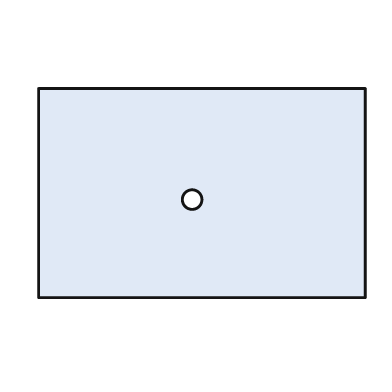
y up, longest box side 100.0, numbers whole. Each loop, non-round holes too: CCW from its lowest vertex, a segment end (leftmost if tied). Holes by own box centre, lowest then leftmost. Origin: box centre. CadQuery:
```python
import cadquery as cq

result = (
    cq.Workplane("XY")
    .moveTo(-50.0, -32.0)
    .lineTo(50.0, -32.0)
    .lineTo(50.0, 32.0)
    .lineTo(-50.0, 32.0)
    .close()
    .moveTo(-3.0, -2.0)
    .circle(3.0)
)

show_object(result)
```